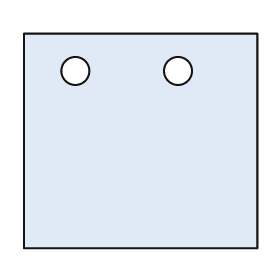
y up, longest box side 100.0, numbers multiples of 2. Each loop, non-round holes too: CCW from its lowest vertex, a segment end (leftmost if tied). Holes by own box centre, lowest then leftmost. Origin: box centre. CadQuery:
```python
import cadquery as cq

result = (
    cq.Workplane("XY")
    .moveTo(-50.0, -46.0)
    .lineTo(50.0, -46.0)
    .lineTo(50.0, 46.0)
    .lineTo(-50.0, 46.0)
    .close()
    .moveTo(-28.0, 30.0)
    .circle(6.0)
    .moveTo(16.0, 30.0)
    .circle(6.0)
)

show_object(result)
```